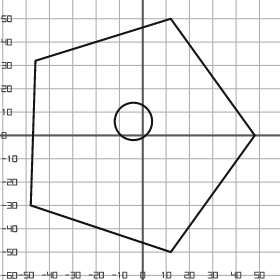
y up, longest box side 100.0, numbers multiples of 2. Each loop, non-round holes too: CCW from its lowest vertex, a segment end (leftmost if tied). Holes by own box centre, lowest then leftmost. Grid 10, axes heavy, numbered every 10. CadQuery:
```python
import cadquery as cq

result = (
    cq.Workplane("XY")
    .moveTo(12.0, -50.0)
    .lineTo(48.0, 0.0)
    .lineTo(12.0, 50.0)
    .lineTo(-46.0, 32.0)
    .lineTo(-48.0, -30.0)
    .close()
    .moveTo(-4.0, 6.0)
    .circle(8.0)
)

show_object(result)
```